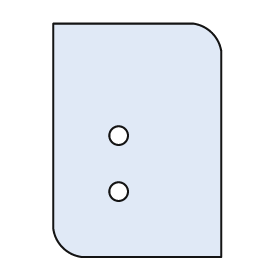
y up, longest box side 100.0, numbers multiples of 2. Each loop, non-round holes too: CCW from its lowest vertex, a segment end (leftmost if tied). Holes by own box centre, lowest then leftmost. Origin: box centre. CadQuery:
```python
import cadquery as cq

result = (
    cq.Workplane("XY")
    .moveTo(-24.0, -50.0)
    .lineTo(36.0, -50.0)
    .lineTo(36.0, 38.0)
    .threePointArc((32.0, 46.0), (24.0, 50.0))
    .lineTo(-36.0, 50.0)
    .lineTo(-36.0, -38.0)
    .threePointArc((-32.0, -46.0), (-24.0, -50.0))
    .close()
    .moveTo(-8.0, -22.0)
    .circle(4.0)
    .moveTo(-8.0, 2.0)
    .circle(4.0)
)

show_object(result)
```